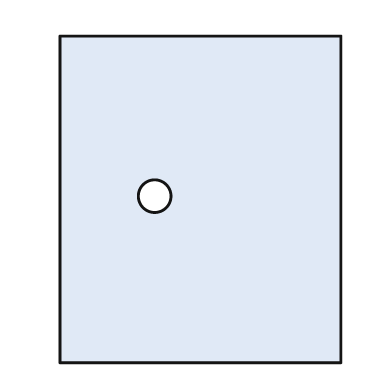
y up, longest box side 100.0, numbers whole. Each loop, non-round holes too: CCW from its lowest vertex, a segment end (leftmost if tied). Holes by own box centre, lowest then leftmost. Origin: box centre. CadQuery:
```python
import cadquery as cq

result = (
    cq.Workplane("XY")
    .moveTo(-43.0, -50.0)
    .lineTo(43.0, -50.0)
    .lineTo(43.0, 50.0)
    .lineTo(-43.0, 50.0)
    .close()
    .moveTo(-14.0, 1.0)
    .circle(5.0)
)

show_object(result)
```